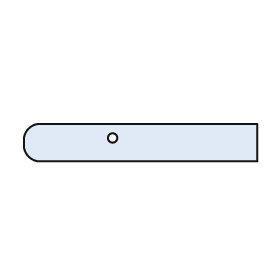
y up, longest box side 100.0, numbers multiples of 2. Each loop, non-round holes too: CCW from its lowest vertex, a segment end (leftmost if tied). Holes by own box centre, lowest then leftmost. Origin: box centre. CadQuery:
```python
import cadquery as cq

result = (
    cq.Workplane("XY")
    .moveTo(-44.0, -8.0)
    .lineTo(50.0, -8.0)
    .lineTo(50.0, 8.0)
    .lineTo(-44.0, 8.0)
    .threePointArc((-48.0, 6.0), (-50.0, 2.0))
    .lineTo(-50.0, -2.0)
    .threePointArc((-48.0, -6.0), (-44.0, -8.0))
    .close()
    .moveTo(-12.0, 2.0)
    .circle(2.0)
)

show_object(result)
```